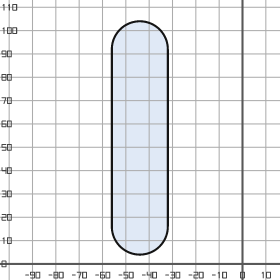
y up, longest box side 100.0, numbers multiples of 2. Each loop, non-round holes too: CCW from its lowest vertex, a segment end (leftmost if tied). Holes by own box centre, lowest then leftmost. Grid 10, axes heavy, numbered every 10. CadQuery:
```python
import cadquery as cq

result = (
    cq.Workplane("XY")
    .moveTo(-56.0, 16.0)
    .threePointArc((-44.0, 4.0), (-32.0, 16.0))
    .lineTo(-32.0, 92.0)
    .threePointArc((-44.0, 104.0), (-56.0, 92.0))
    .close()
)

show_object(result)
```